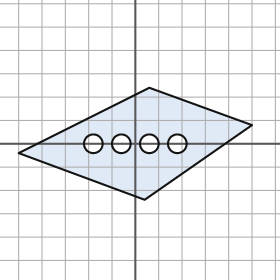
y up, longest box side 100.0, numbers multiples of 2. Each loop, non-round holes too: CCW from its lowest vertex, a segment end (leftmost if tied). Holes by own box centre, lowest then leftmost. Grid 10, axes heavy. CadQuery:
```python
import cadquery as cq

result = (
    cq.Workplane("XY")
    .moveTo(4.0, -24.0)
    .lineTo(50.0, 8.0)
    .lineTo(6.0, 24.0)
    .lineTo(-50.0, -4.0)
    .close()
    .moveTo(-18.0, 0.0)
    .circle(4.0)
    .moveTo(-6.0, 0.0)
    .circle(4.0)
    .moveTo(6.0, 0.0)
    .circle(4.0)
    .moveTo(18.0, 0.0)
    .circle(4.0)
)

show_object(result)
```